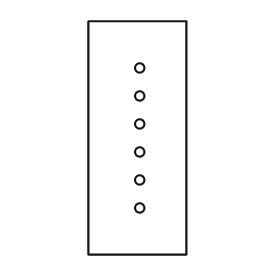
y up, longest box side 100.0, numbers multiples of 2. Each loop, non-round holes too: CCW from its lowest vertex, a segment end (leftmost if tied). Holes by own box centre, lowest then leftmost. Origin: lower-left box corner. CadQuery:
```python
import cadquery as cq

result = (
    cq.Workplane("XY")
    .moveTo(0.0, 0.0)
    .lineTo(42.0, 0.0)
    .lineTo(42.0, 100.0)
    .lineTo(0.0, 100.0)
    .close()
    .moveTo(22.0, 20.0)
    .circle(2.0)
    .moveTo(22.0, 32.0)
    .circle(2.0)
    .moveTo(22.0, 44.0)
    .circle(2.0)
    .moveTo(22.0, 56.0)
    .circle(2.0)
    .moveTo(22.0, 68.0)
    .circle(2.0)
    .moveTo(22.0, 80.0)
    .circle(2.0)
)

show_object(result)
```